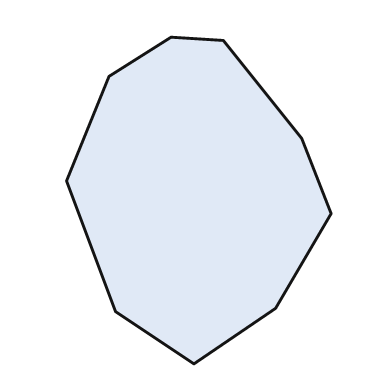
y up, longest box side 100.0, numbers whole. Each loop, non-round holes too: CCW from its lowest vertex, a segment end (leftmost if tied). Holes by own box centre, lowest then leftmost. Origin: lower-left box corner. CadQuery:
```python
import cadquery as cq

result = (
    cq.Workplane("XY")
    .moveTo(39.0, 0.0)
    .lineTo(64.0, 17.0)
    .lineTo(81.0, 46.0)
    .lineTo(72.0, 69.0)
    .lineTo(48.0, 99.0)
    .lineTo(32.0, 100.0)
    .lineTo(13.0, 88.0)
    .lineTo(0.0, 56.0)
    .lineTo(15.0, 16.0)
    .close()
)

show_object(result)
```